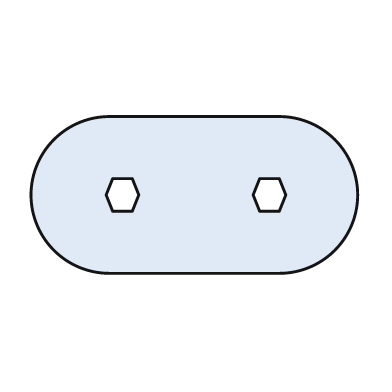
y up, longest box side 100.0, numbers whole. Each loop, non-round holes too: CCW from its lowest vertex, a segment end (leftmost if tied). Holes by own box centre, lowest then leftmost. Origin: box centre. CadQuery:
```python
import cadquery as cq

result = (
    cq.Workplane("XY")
    .moveTo(-26.0, -24.0)
    .lineTo(26.0, -24.0)
    .threePointArc((50.0, 0.0), (26.0, 24.0))
    .lineTo(-26.0, 24.0)
    .threePointArc((-50.0, 0.0), (-26.0, -24.0))
    .close()
    .moveTo(-25.0, -5.0)
    .lineTo(-19.0, -5.0)
    .lineTo(-17.0, 0.0)
    .lineTo(-19.0, 5.0)
    .lineTo(-25.0, 5.0)
    .lineTo(-27.0, 0.0)
    .close()
    .moveTo(20.0, -5.0)
    .lineTo(26.0, -5.0)
    .lineTo(28.0, 0.0)
    .lineTo(26.0, 5.0)
    .lineTo(20.0, 5.0)
    .lineTo(18.0, 0.0)
    .close()
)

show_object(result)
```